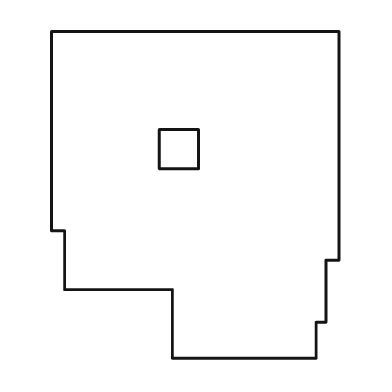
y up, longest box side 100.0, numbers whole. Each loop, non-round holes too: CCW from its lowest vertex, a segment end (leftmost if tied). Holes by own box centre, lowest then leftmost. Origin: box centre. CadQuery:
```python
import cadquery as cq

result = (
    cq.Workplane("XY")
    .moveTo(-7.0, -50.0)
    .lineTo(37.0, -50.0)
    .lineTo(37.0, -39.0)
    .lineTo(40.0, -39.0)
    .lineTo(40.0, -20.0)
    .lineTo(44.0, -20.0)
    .lineTo(44.0, 50.0)
    .lineTo(-44.0, 50.0)
    .lineTo(-44.0, -11.0)
    .lineTo(-40.0, -11.0)
    .lineTo(-40.0, -29.0)
    .lineTo(-7.0, -29.0)
    .close()
    .moveTo(-11.0, 8.0)
    .lineTo(1.0, 8.0)
    .lineTo(1.0, 20.0)
    .lineTo(-11.0, 20.0)
    .close()
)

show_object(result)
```